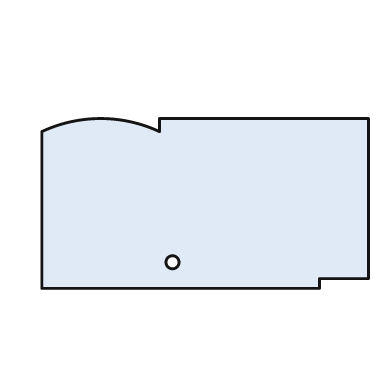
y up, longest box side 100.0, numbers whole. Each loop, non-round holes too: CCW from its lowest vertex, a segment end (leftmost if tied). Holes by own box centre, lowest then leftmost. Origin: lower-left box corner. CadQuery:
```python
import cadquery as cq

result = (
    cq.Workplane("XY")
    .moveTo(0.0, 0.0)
    .lineTo(85.0, 0.0)
    .lineTo(85.0, 3.0)
    .lineTo(100.0, 3.0)
    .lineTo(100.0, 52.0)
    .lineTo(36.0, 52.0)
    .lineTo(36.0, 48.0)
    .threePointArc((18.0, 52.0), (0.0, 48.0))
    .close()
    .moveTo(40.0, 8.0)
    .circle(2.0)
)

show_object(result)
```